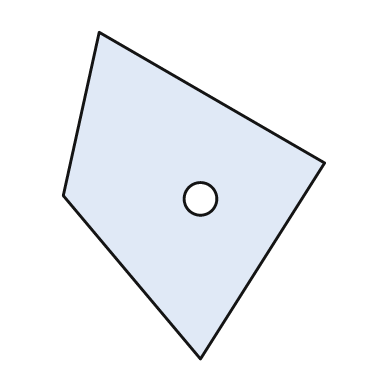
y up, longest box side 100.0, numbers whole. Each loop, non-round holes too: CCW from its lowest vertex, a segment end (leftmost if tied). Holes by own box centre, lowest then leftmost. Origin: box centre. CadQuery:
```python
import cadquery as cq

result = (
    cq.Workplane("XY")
    .moveTo(2.0, -50.0)
    .lineTo(40.0, 10.0)
    .lineTo(-29.0, 50.0)
    .lineTo(-40.0, 0.0)
    .close()
    .moveTo(2.0, -1.0)
    .circle(5.0)
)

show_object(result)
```